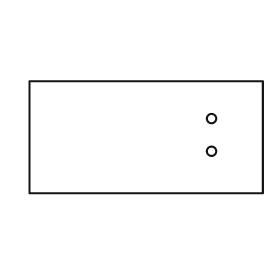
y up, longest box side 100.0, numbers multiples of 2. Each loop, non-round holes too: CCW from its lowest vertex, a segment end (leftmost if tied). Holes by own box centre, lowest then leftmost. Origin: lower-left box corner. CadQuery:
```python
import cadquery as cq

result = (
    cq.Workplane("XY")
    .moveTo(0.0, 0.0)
    .lineTo(100.0, 0.0)
    .lineTo(100.0, 48.0)
    .lineTo(0.0, 48.0)
    .close()
    .moveTo(78.0, 18.0)
    .circle(2.0)
    .moveTo(78.0, 32.0)
    .circle(2.0)
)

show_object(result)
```